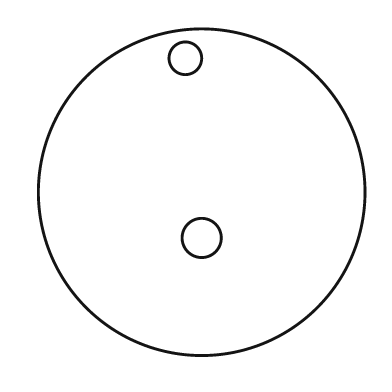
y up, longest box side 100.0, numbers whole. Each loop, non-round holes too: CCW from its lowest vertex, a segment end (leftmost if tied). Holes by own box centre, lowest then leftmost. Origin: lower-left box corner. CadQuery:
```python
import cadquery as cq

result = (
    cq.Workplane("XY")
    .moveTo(50.0, 50.0)
    .circle(50.0)
    .moveTo(50.0, 36.0)
    .circle(6.0)
    .moveTo(45.0, 91.0)
    .circle(5.0)
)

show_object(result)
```